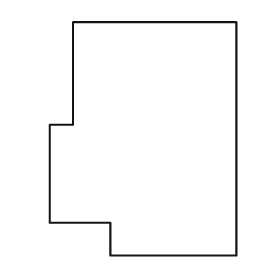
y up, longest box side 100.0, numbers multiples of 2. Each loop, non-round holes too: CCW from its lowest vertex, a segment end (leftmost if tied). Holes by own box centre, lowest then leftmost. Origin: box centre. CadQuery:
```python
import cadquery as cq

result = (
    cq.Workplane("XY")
    .moveTo(-14.0, -50.0)
    .lineTo(40.0, -50.0)
    .lineTo(40.0, 50.0)
    .lineTo(-30.0, 50.0)
    .lineTo(-30.0, 6.0)
    .lineTo(-40.0, 6.0)
    .lineTo(-40.0, -36.0)
    .lineTo(-14.0, -36.0)
    .close()
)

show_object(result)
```